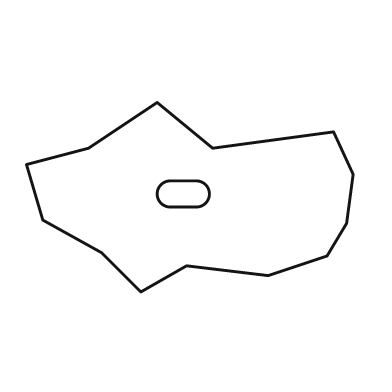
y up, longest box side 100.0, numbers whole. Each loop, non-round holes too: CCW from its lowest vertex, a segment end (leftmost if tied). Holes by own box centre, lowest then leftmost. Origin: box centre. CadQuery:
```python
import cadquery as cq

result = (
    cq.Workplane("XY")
    .moveTo(-15.0, -29.0)
    .lineTo(-1.0, -21.0)
    .lineTo(24.0, -24.0)
    .lineTo(42.0, -18.0)
    .lineTo(48.0, -8.0)
    .lineTo(50.0, 7.0)
    .lineTo(44.0, 20.0)
    .lineTo(7.0, 15.0)
    .lineTo(-10.0, 29.0)
    .lineTo(-31.0, 15.0)
    .lineTo(-50.0, 10.0)
    .lineTo(-45.0, -7.0)
    .lineTo(-27.0, -17.0)
    .close()
    .moveTo(-6.0, -3.0)
    .lineTo(2.0, -3.0)
    .threePointArc((6.0, 1.0), (2.0, 5.0))
    .lineTo(-6.0, 5.0)
    .threePointArc((-10.0, 1.0), (-6.0, -3.0))
    .close()
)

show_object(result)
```